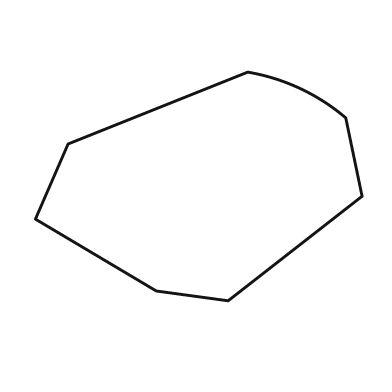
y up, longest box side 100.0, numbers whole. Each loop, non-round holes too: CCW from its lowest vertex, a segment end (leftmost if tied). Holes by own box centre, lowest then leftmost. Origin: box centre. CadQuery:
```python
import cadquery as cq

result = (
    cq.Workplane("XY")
    .moveTo(9.0, -35.0)
    .lineTo(50.0, -3.0)
    .lineTo(45.0, 21.0)
    .threePointArc((31.0, 30.0), (15.0, 35.0))
    .lineTo(-40.0, 13.0)
    .lineTo(-50.0, -10.0)
    .lineTo(-13.0, -32.0)
    .close()
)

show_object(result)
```